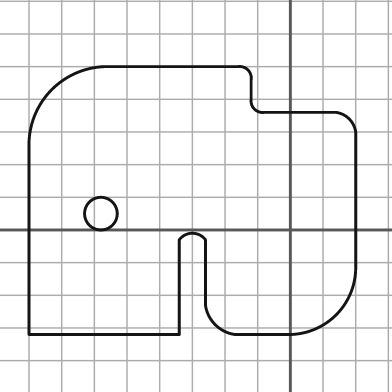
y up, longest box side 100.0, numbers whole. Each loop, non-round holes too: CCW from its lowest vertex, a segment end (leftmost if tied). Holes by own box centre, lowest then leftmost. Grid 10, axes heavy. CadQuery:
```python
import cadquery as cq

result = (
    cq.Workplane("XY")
    .moveTo(-80.0, -32.0)
    .lineTo(-34.0, -32.0)
    .lineTo(-34.0, -3.0)
    .threePointArc((-30.0, -1.0), (-26.0, -3.0))
    .lineTo(-26.0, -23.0)
    .threePointArc((-23.0, -29.0), (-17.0, -32.0))
    .lineTo(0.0, -32.0)
    .threePointArc((14.0, -26.0), (20.0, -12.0))
    .lineTo(20.0, 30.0)
    .threePointArc((18.0, 34.0), (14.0, 36.0))
    .lineTo(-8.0, 36.0)
    .threePointArc((-11.0, 37.0), (-12.0, 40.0))
    .lineTo(-12.0, 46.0)
    .threePointArc((-13.0, 49.0), (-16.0, 50.0))
    .lineTo(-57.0, 50.0)
    .threePointArc((-73.0, 43.0), (-80.0, 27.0))
    .close()
    .moveTo(-58.0, 5.0)
    .circle(5.0)
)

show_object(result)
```